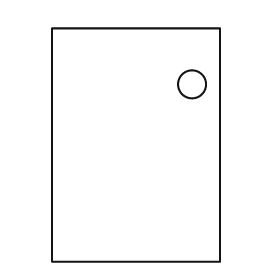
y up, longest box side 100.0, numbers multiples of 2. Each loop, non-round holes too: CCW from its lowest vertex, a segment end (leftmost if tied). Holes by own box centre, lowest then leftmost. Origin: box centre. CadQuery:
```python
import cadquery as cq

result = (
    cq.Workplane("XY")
    .moveTo(-36.0, -50.0)
    .lineTo(36.0, -50.0)
    .lineTo(36.0, 50.0)
    .lineTo(-36.0, 50.0)
    .close()
    .moveTo(24.0, 26.0)
    .circle(6.0)
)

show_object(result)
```